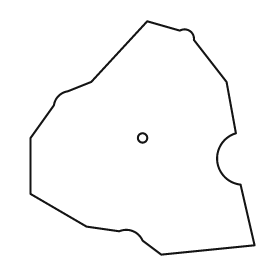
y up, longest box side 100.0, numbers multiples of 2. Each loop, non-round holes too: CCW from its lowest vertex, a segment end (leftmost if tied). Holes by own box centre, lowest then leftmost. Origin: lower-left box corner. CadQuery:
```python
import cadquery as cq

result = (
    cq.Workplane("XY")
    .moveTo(56.0, 0.0)
    .lineTo(96.0, 4.0)
    .lineTo(90.0, 30.0)
    .threePointArc((80.0, 40.0), (88.0, 52.0))
    .lineTo(84.0, 74.0)
    .lineTo(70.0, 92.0)
    .threePointArc((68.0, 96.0), (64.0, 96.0))
    .lineTo(50.0, 100.0)
    .lineTo(26.0, 74.0)
    .lineTo(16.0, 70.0)
    .threePointArc((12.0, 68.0), (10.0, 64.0))
    .lineTo(0.0, 50.0)
    .lineTo(0.0, 26.0)
    .lineTo(24.0, 12.0)
    .lineTo(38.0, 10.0)
    .threePointArc((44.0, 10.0), (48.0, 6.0))
    .close()
    .moveTo(48.0, 50.0)
    .circle(2.0)
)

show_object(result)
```